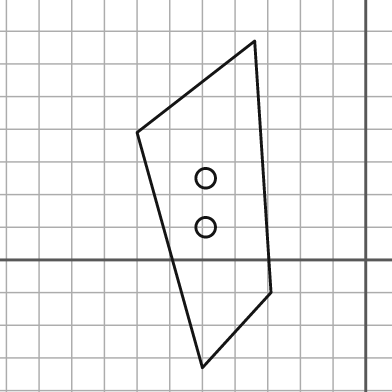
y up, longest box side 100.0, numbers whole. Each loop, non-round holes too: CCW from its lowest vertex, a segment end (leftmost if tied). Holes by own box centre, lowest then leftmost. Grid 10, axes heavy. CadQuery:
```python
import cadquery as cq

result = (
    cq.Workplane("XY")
    .moveTo(-50.0, -33.0)
    .lineTo(-29.0, -10.0)
    .lineTo(-34.0, 67.0)
    .lineTo(-70.0, 39.0)
    .close()
    .moveTo(-49.0, 10.0)
    .circle(3.0)
    .moveTo(-49.0, 25.0)
    .circle(3.0)
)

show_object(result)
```